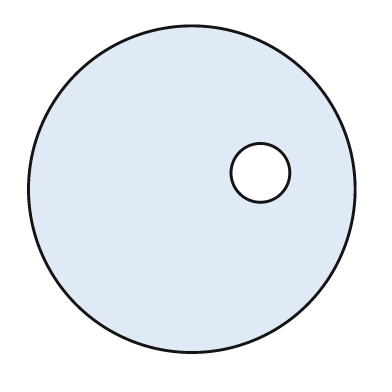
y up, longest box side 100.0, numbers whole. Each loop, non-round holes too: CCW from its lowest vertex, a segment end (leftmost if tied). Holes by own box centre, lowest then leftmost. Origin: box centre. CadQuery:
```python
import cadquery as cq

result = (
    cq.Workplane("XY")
    .moveTo(0.0, 0.0)
    .circle(50.0)
    .moveTo(21.0, 5.0)
    .circle(9.0)
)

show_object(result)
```